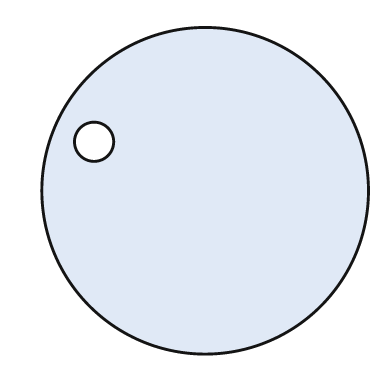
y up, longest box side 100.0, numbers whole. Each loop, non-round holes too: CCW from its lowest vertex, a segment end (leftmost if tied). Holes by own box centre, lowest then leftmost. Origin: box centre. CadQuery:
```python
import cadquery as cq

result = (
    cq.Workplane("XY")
    .moveTo(0.0, 0.0)
    .circle(50.0)
    .moveTo(-34.0, 15.0)
    .circle(6.0)
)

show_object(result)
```